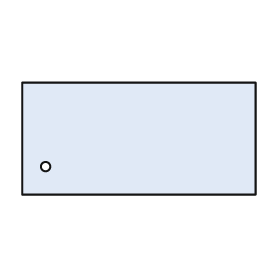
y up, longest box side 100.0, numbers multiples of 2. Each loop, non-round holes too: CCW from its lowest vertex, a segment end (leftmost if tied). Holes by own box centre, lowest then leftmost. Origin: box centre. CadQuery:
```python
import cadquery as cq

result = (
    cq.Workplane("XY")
    .moveTo(-50.0, -24.0)
    .lineTo(50.0, -24.0)
    .lineTo(50.0, 24.0)
    .lineTo(-50.0, 24.0)
    .close()
    .moveTo(-40.0, -12.0)
    .circle(2.0)
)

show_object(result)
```